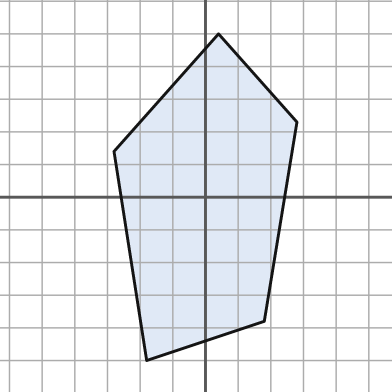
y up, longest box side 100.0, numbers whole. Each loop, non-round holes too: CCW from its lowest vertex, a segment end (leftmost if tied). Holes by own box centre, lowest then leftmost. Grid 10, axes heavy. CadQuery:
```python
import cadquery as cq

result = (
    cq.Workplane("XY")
    .moveTo(-18.0, -50.0)
    .lineTo(18.0, -38.0)
    .lineTo(28.0, 23.0)
    .lineTo(4.0, 50.0)
    .lineTo(-28.0, 14.0)
    .close()
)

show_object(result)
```